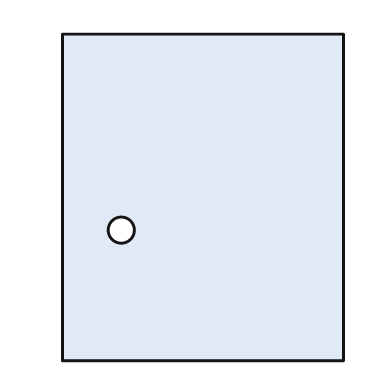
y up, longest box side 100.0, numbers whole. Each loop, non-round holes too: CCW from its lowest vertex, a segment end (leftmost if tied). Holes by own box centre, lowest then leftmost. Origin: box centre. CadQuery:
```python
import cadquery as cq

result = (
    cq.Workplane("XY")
    .moveTo(-43.0, -50.0)
    .lineTo(43.0, -50.0)
    .lineTo(43.0, 50.0)
    .lineTo(-43.0, 50.0)
    .close()
    .moveTo(-25.0, -10.0)
    .circle(4.0)
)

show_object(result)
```